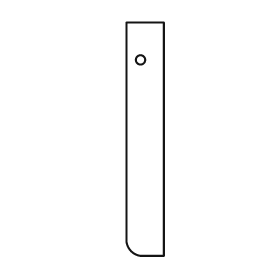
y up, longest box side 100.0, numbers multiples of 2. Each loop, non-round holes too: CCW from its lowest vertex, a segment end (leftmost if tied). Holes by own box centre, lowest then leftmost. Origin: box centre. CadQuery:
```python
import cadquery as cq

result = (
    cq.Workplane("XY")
    .moveTo(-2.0, -50.0)
    .lineTo(8.0, -50.0)
    .lineTo(8.0, 50.0)
    .lineTo(-8.0, 50.0)
    .lineTo(-8.0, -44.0)
    .threePointArc((-6.0, -48.0), (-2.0, -50.0))
    .close()
    .moveTo(-2.0, 34.0)
    .circle(2.0)
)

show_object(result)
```